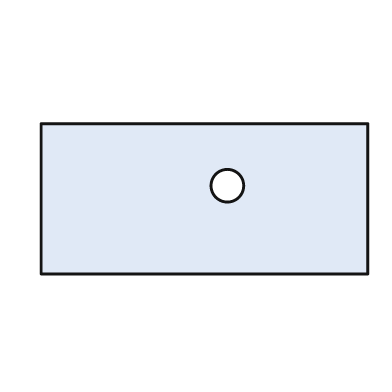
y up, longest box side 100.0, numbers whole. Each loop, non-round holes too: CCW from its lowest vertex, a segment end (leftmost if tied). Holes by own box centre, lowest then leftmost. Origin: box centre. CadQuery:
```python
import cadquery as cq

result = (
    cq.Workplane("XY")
    .moveTo(-50.0, -23.0)
    .lineTo(50.0, -23.0)
    .lineTo(50.0, 23.0)
    .lineTo(-50.0, 23.0)
    .close()
    .moveTo(7.0, 4.0)
    .circle(5.0)
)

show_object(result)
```